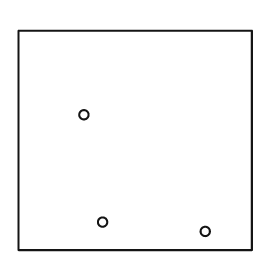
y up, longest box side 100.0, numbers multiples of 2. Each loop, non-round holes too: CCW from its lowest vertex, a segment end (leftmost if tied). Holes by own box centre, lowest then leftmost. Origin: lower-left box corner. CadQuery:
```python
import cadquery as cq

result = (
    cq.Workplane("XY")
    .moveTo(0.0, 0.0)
    .lineTo(100.0, 0.0)
    .lineTo(100.0, 94.0)
    .lineTo(0.0, 94.0)
    .close()
    .moveTo(80.0, 8.0)
    .circle(2.0)
    .moveTo(36.0, 12.0)
    .circle(2.0)
    .moveTo(28.0, 58.0)
    .circle(2.0)
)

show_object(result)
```